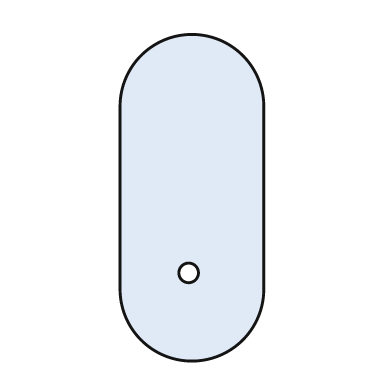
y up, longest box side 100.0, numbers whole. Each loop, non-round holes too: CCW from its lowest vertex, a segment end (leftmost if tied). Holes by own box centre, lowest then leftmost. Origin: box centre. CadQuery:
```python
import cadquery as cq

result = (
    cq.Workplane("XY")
    .moveTo(-22.0, -28.0)
    .threePointArc((0.0, -50.0), (22.0, -28.0))
    .lineTo(22.0, 28.0)
    .threePointArc((0.0, 50.0), (-22.0, 28.0))
    .close()
    .moveTo(-1.0, -23.0)
    .circle(3.0)
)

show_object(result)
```